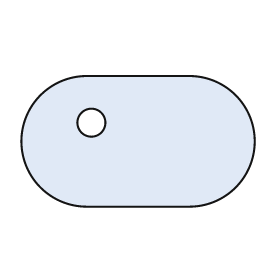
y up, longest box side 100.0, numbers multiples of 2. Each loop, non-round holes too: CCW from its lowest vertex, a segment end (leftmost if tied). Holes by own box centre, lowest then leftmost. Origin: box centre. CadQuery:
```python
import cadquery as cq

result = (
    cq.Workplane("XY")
    .moveTo(-22.0, -28.0)
    .lineTo(22.0, -28.0)
    .threePointArc((50.0, 0.0), (22.0, 28.0))
    .lineTo(-22.0, 28.0)
    .threePointArc((-50.0, 0.0), (-22.0, -28.0))
    .close()
    .moveTo(-20.0, 8.0)
    .circle(6.0)
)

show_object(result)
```